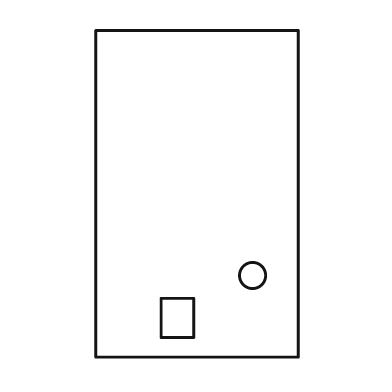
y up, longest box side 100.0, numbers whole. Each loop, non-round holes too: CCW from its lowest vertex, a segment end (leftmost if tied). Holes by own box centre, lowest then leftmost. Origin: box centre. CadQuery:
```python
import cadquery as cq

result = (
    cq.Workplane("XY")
    .moveTo(-31.0, -50.0)
    .lineTo(31.0, -50.0)
    .lineTo(31.0, 50.0)
    .lineTo(-31.0, 50.0)
    .close()
    .moveTo(-11.0, -44.0)
    .lineTo(-1.0, -44.0)
    .lineTo(-1.0, -32.0)
    .lineTo(-11.0, -32.0)
    .close()
    .moveTo(17.0, -25.0)
    .circle(4.0)
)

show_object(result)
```